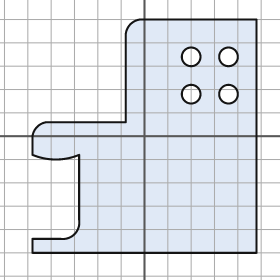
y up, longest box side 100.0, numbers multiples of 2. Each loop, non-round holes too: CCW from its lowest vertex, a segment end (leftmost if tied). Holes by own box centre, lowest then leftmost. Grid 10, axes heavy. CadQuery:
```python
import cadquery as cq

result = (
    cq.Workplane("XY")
    .moveTo(-48.0, -50.0)
    .lineTo(48.0, -50.0)
    .lineTo(48.0, 50.0)
    .lineTo(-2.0, 50.0)
    .threePointArc((-6.0, 48.0), (-8.0, 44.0))
    .lineTo(-8.0, 6.0)
    .lineTo(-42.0, 6.0)
    .threePointArc((-46.0, 4.0), (-48.0, 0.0))
    .lineTo(-48.0, -8.0)
    .threePointArc((-38.0, -10.0), (-28.0, -8.0))
    .lineTo(-28.0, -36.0)
    .threePointArc((-30.0, -42.0), (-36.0, -44.0))
    .lineTo(-48.0, -44.0)
    .close()
    .moveTo(20.0, 18.0)
    .circle(4.0)
    .moveTo(36.0, 18.0)
    .circle(4.0)
    .moveTo(20.0, 34.0)
    .circle(4.0)
    .moveTo(36.0, 34.0)
    .circle(4.0)
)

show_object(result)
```